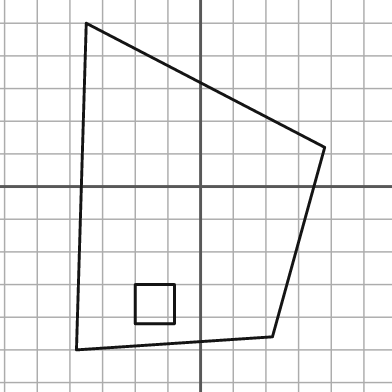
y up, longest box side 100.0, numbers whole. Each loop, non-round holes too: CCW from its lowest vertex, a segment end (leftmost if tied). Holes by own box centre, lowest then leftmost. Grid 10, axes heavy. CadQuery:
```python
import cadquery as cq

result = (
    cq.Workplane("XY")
    .moveTo(-38.0, -50.0)
    .lineTo(22.0, -46.0)
    .lineTo(38.0, 12.0)
    .lineTo(-35.0, 50.0)
    .close()
    .moveTo(-20.0, -42.0)
    .lineTo(-8.0, -42.0)
    .lineTo(-8.0, -30.0)
    .lineTo(-20.0, -30.0)
    .close()
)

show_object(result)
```